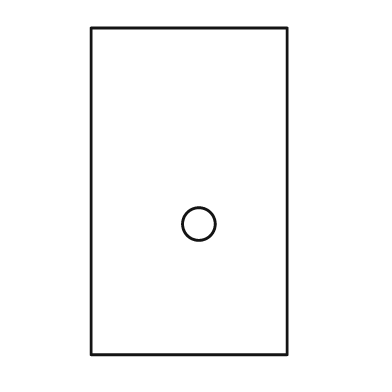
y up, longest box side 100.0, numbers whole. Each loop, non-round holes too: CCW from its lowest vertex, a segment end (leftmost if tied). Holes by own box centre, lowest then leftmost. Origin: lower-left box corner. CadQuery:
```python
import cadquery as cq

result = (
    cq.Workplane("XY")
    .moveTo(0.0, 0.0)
    .lineTo(60.0, 0.0)
    .lineTo(60.0, 100.0)
    .lineTo(0.0, 100.0)
    .close()
    .moveTo(33.0, 40.0)
    .circle(5.0)
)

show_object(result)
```